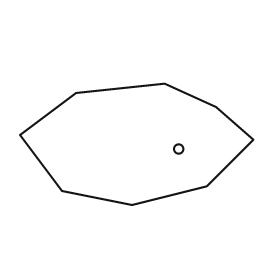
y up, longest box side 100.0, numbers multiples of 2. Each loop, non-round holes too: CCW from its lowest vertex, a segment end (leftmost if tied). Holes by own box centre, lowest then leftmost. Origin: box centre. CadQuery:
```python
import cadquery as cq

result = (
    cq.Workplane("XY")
    .moveTo(-2.0, -26.0)
    .lineTo(30.0, -18.0)
    .lineTo(50.0, 2.0)
    .lineTo(34.0, 16.0)
    .lineTo(12.0, 26.0)
    .lineTo(-26.0, 22.0)
    .lineTo(-50.0, 4.0)
    .lineTo(-32.0, -20.0)
    .close()
    .moveTo(18.0, -2.0)
    .circle(2.0)
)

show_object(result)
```